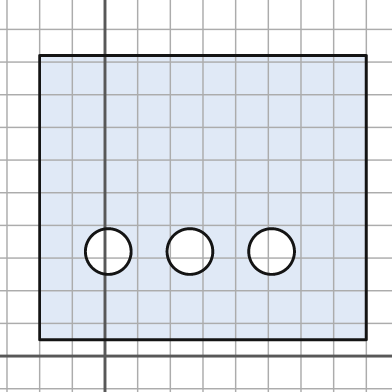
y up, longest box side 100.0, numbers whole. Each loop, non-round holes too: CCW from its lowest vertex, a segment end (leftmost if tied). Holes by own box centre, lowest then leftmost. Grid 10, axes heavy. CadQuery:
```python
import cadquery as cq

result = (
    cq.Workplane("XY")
    .moveTo(-20.0, 5.0)
    .lineTo(80.0, 5.0)
    .lineTo(80.0, 92.0)
    .lineTo(-20.0, 92.0)
    .close()
    .moveTo(1.0, 32.0)
    .circle(7.0)
    .moveTo(26.0, 32.0)
    .circle(7.0)
    .moveTo(51.0, 32.0)
    .circle(7.0)
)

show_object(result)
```